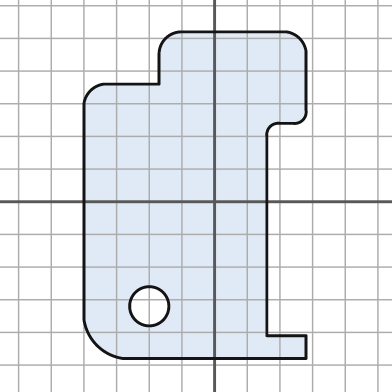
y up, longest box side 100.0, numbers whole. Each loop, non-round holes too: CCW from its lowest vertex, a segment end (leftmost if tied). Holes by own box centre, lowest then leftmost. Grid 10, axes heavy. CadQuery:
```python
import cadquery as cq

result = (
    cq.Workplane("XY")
    .moveTo(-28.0, -48.0)
    .lineTo(28.0, -48.0)
    .lineTo(28.0, -41.0)
    .lineTo(16.0, -41.0)
    .lineTo(16.0, 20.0)
    .threePointArc((17.0, 23.0), (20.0, 24.0))
    .lineTo(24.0, 24.0)
    .threePointArc((27.0, 25.0), (28.0, 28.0))
    .lineTo(28.0, 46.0)
    .threePointArc((26.0, 50.0), (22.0, 52.0))
    .lineTo(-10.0, 52.0)
    .threePointArc((-15.0, 50.0), (-17.0, 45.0))
    .lineTo(-17.0, 36.0)
    .lineTo(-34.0, 36.0)
    .threePointArc((-38.0, 34.0), (-40.0, 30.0))
    .lineTo(-40.0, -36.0)
    .threePointArc((-36.0, -44.0), (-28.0, -48.0))
    .close()
    .moveTo(-20.0, -32.0)
    .circle(6.0)
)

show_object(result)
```